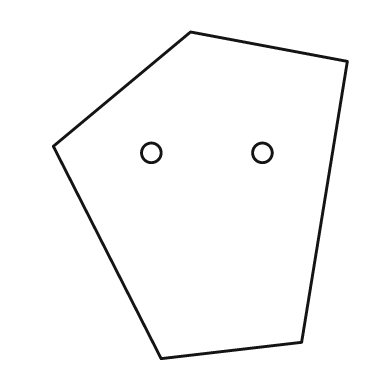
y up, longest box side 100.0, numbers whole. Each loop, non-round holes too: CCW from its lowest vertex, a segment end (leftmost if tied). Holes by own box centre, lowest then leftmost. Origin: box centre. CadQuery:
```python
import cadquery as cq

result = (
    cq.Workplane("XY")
    .moveTo(-12.0, -50.0)
    .lineTo(31.0, -45.0)
    .lineTo(45.0, 41.0)
    .lineTo(-3.0, 50.0)
    .lineTo(-45.0, 15.0)
    .close()
    .moveTo(-15.0, 13.0)
    .circle(3.0)
    .moveTo(19.0, 13.0)
    .circle(3.0)
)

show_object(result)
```